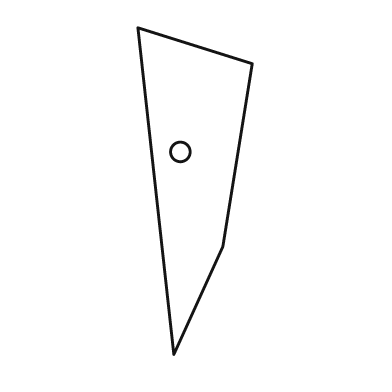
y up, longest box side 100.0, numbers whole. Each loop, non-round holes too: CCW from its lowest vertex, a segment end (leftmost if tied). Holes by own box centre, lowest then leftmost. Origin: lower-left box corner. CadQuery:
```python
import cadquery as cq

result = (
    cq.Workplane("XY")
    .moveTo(11.0, 0.0)
    .lineTo(26.0, 33.0)
    .lineTo(35.0, 89.0)
    .lineTo(0.0, 100.0)
    .close()
    .moveTo(13.0, 62.0)
    .circle(3.0)
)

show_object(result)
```